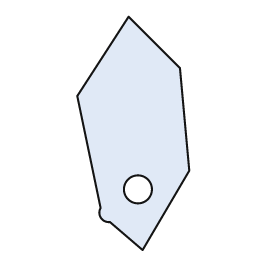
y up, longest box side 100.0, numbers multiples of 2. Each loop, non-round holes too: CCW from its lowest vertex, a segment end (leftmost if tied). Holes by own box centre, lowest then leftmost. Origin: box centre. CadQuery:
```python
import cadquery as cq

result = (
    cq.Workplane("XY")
    .moveTo(4.0, -50.0)
    .lineTo(24.0, -16.0)
    .lineTo(20.0, 28.0)
    .lineTo(-2.0, 50.0)
    .lineTo(-24.0, 16.0)
    .lineTo(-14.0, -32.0)
    .threePointArc((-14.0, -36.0), (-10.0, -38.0))
    .close()
    .moveTo(2.0, -24.0)
    .circle(6.0)
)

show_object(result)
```